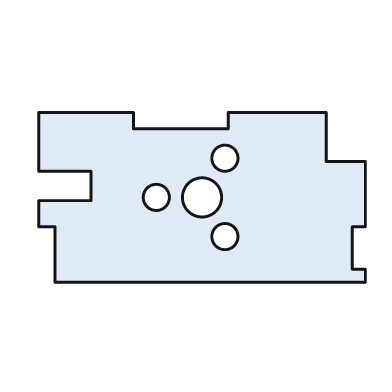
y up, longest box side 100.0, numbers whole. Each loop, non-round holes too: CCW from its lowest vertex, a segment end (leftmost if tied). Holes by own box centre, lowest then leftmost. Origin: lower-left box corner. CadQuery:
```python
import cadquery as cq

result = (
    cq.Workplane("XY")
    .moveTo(5.0, 0.0)
    .lineTo(100.0, 0.0)
    .lineTo(100.0, 4.0)
    .lineTo(96.0, 4.0)
    .lineTo(96.0, 17.0)
    .lineTo(100.0, 17.0)
    .lineTo(100.0, 37.0)
    .lineTo(88.0, 37.0)
    .lineTo(88.0, 52.0)
    .lineTo(58.0, 52.0)
    .lineTo(58.0, 47.0)
    .lineTo(29.0, 47.0)
    .lineTo(29.0, 52.0)
    .lineTo(0.0, 52.0)
    .lineTo(0.0, 34.0)
    .lineTo(16.0, 34.0)
    .lineTo(16.0, 25.0)
    .lineTo(0.0, 25.0)
    .lineTo(0.0, 17.0)
    .lineTo(5.0, 17.0)
    .close()
    .moveTo(57.0, 14.0)
    .circle(4.0)
    .moveTo(36.0, 26.0)
    .circle(4.0)
    .moveTo(50.0, 26.0)
    .circle(6.0)
    .moveTo(57.0, 38.0)
    .circle(4.0)
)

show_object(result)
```